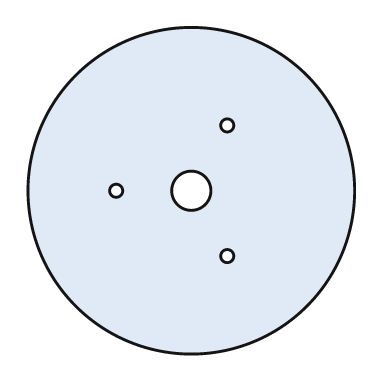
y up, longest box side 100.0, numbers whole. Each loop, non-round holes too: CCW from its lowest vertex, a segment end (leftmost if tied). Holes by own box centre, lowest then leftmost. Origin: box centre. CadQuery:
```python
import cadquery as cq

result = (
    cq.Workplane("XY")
    .moveTo(0.0, 0.0)
    .circle(50.0)
    .moveTo(11.0, -20.0)
    .circle(2.0)
    .moveTo(-23.0, 0.0)
    .circle(2.0)
    .moveTo(0.0, 0.0)
    .circle(6.0)
    .moveTo(11.0, 20.0)
    .circle(2.0)
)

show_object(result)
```